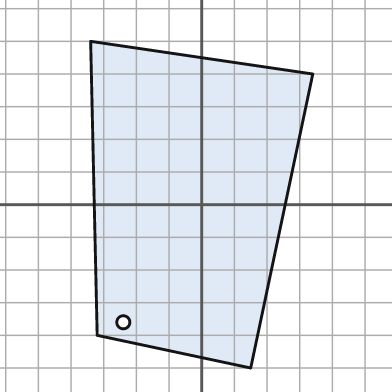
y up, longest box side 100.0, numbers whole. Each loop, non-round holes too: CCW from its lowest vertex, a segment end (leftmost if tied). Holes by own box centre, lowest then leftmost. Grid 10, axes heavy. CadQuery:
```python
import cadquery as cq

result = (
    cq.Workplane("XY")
    .moveTo(15.0, -50.0)
    .lineTo(34.0, 40.0)
    .lineTo(-34.0, 50.0)
    .lineTo(-32.0, -40.0)
    .close()
    .moveTo(-24.0, -36.0)
    .circle(2.0)
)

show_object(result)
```